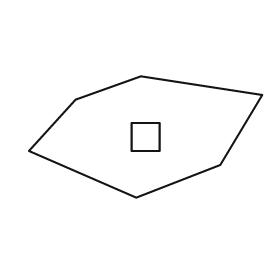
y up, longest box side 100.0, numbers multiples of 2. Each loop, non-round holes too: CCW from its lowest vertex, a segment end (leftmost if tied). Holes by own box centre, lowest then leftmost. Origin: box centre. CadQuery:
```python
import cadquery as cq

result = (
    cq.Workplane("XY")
    .moveTo(-4.0, -26.0)
    .lineTo(32.0, -12.0)
    .lineTo(50.0, 18.0)
    .lineTo(-2.0, 26.0)
    .lineTo(-30.0, 16.0)
    .lineTo(-50.0, -6.0)
    .close()
    .moveTo(-6.0, -6.0)
    .lineTo(6.0, -6.0)
    .lineTo(6.0, 6.0)
    .lineTo(-6.0, 6.0)
    .close()
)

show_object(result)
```